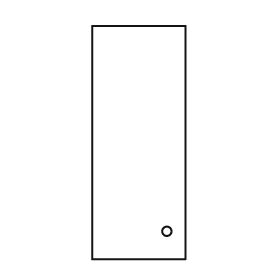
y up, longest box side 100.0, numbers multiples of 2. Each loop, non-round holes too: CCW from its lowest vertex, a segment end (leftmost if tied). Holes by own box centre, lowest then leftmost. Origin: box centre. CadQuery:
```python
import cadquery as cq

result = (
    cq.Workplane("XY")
    .moveTo(-20.0, -50.0)
    .lineTo(20.0, -50.0)
    .lineTo(20.0, 50.0)
    .lineTo(-20.0, 50.0)
    .close()
    .moveTo(12.0, -38.0)
    .circle(2.0)
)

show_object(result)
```